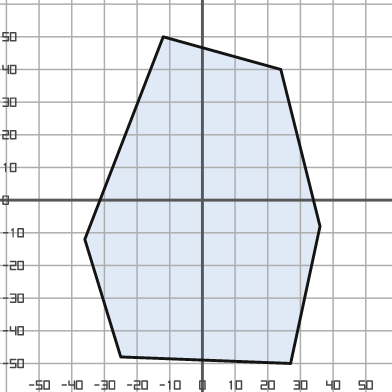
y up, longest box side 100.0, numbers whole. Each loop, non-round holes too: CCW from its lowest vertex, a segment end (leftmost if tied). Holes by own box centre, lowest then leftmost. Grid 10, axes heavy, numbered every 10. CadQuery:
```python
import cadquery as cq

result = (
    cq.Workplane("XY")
    .moveTo(27.0, -50.0)
    .lineTo(36.0, -8.0)
    .lineTo(24.0, 40.0)
    .lineTo(-12.0, 50.0)
    .lineTo(-36.0, -12.0)
    .lineTo(-25.0, -48.0)
    .close()
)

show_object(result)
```